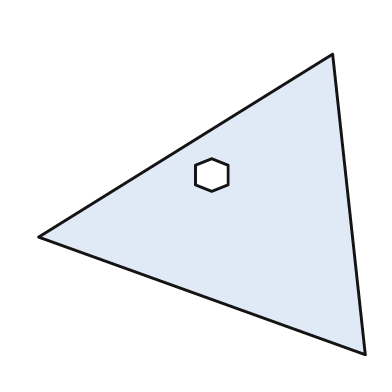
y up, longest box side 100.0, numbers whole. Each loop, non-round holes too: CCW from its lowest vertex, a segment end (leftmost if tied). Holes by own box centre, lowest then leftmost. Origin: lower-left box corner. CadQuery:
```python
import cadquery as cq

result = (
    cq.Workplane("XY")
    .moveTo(100.0, 0.0)
    .lineTo(90.0, 92.0)
    .lineTo(0.0, 36.0)
    .close()
    .moveTo(53.0, 50.0)
    .lineTo(58.0, 52.0)
    .lineTo(58.0, 58.0)
    .lineTo(53.0, 60.0)
    .lineTo(48.0, 58.0)
    .lineTo(48.0, 52.0)
    .close()
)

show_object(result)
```